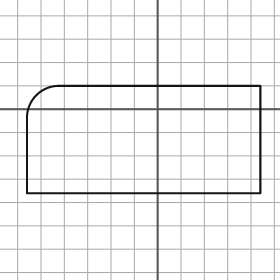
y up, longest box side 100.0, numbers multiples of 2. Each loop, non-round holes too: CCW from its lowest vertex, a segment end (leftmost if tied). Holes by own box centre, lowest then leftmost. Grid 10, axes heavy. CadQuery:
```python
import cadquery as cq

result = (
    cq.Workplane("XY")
    .moveTo(-56.0, -36.0)
    .lineTo(44.0, -36.0)
    .lineTo(44.0, 10.0)
    .lineTo(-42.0, 10.0)
    .threePointArc((-52.0, 6.0), (-56.0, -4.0))
    .close()
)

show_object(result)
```